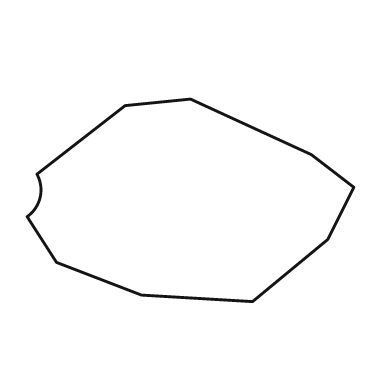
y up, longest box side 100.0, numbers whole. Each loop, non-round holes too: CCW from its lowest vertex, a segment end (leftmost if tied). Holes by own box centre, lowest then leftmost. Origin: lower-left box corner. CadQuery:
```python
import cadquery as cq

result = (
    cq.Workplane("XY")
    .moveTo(69.0, 0.0)
    .lineTo(92.0, 19.0)
    .lineTo(100.0, 35.0)
    .lineTo(87.0, 45.0)
    .lineTo(50.0, 62.0)
    .lineTo(30.0, 60.0)
    .lineTo(3.0, 39.0)
    .threePointArc((4.0, 32.0), (0.0, 26.0))
    .lineTo(9.0, 12.0)
    .lineTo(35.0, 2.0)
    .close()
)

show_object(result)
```